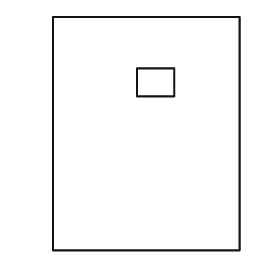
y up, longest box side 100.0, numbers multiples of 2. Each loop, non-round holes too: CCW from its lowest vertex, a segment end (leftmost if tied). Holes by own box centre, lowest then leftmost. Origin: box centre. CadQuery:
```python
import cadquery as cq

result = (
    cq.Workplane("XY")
    .moveTo(-40.0, -50.0)
    .lineTo(40.0, -50.0)
    .lineTo(40.0, 50.0)
    .lineTo(-40.0, 50.0)
    .close()
    .moveTo(-4.0, 16.0)
    .lineTo(12.0, 16.0)
    .lineTo(12.0, 28.0)
    .lineTo(-4.0, 28.0)
    .close()
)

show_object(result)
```